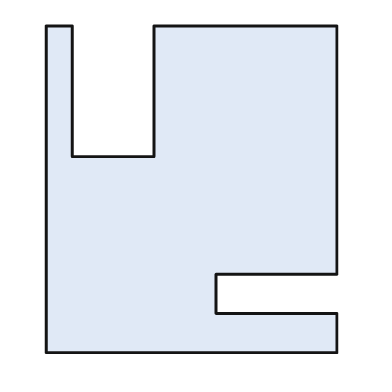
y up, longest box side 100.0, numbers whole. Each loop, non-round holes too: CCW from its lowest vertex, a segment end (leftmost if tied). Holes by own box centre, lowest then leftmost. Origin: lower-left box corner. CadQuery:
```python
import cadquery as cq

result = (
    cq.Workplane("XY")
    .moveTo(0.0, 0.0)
    .lineTo(89.0, 0.0)
    .lineTo(89.0, 12.0)
    .lineTo(52.0, 12.0)
    .lineTo(52.0, 24.0)
    .lineTo(89.0, 24.0)
    .lineTo(89.0, 100.0)
    .lineTo(33.0, 100.0)
    .lineTo(33.0, 60.0)
    .lineTo(8.0, 60.0)
    .lineTo(8.0, 100.0)
    .lineTo(0.0, 100.0)
    .close()
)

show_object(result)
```